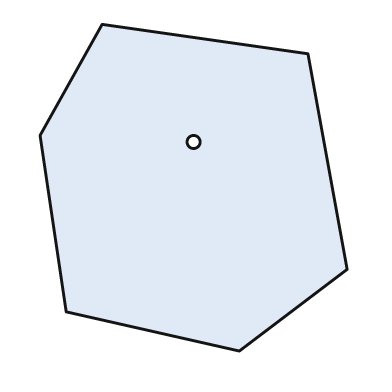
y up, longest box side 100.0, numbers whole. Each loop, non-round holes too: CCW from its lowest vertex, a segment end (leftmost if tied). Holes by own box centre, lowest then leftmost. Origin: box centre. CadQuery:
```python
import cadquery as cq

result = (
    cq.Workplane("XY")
    .moveTo(14.0, -50.0)
    .lineTo(47.0, -25.0)
    .lineTo(35.0, 41.0)
    .lineTo(-28.0, 50.0)
    .lineTo(-47.0, 16.0)
    .lineTo(-39.0, -38.0)
    .close()
    .moveTo(0.0, 14.0)
    .circle(2.0)
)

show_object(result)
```